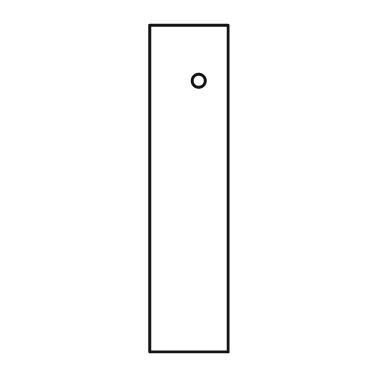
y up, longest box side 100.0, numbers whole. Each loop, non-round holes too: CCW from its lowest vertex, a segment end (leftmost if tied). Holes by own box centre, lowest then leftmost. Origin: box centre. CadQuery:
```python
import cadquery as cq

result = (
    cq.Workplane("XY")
    .moveTo(-12.0, -50.0)
    .lineTo(12.0, -50.0)
    .lineTo(12.0, 50.0)
    .lineTo(-12.0, 50.0)
    .close()
    .moveTo(3.0, 33.0)
    .circle(2.0)
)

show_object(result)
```